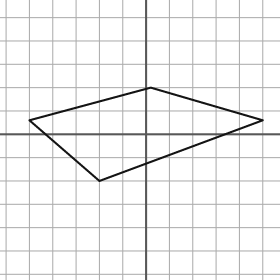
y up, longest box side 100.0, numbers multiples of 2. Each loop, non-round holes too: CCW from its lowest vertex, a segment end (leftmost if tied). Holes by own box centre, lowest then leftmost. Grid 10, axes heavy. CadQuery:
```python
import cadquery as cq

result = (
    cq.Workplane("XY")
    .moveTo(-20.0, -20.0)
    .lineTo(50.0, 6.0)
    .lineTo(2.0, 20.0)
    .lineTo(-50.0, 6.0)
    .close()
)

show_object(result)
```